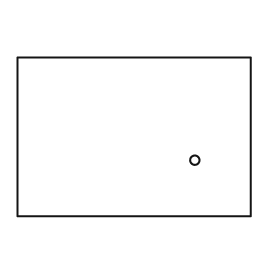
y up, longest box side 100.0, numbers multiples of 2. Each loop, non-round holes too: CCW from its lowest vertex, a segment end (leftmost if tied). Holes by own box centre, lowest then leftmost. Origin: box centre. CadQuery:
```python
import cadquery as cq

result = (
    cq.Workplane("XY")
    .moveTo(-50.0, -34.0)
    .lineTo(50.0, -34.0)
    .lineTo(50.0, 34.0)
    .lineTo(-50.0, 34.0)
    .close()
    .moveTo(26.0, -10.0)
    .circle(2.0)
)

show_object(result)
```